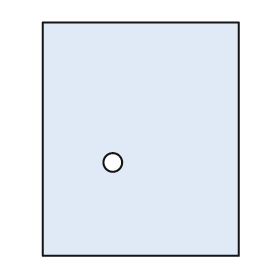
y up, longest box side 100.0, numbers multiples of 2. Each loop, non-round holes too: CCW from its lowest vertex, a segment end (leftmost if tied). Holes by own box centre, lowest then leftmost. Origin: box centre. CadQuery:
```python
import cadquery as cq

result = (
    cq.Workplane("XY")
    .moveTo(-42.0, -50.0)
    .lineTo(42.0, -50.0)
    .lineTo(42.0, 50.0)
    .lineTo(-42.0, 50.0)
    .close()
    .moveTo(-12.0, -10.0)
    .circle(4.0)
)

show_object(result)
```